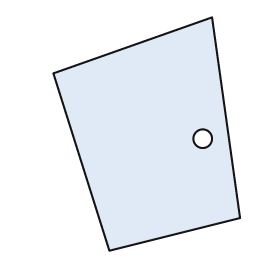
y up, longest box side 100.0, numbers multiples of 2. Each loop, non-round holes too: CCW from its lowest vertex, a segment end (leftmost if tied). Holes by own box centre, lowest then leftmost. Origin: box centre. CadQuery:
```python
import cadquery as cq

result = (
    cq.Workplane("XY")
    .moveTo(-16.0, -50.0)
    .lineTo(40.0, -36.0)
    .lineTo(28.0, 50.0)
    .lineTo(-40.0, 26.0)
    .close()
    .moveTo(24.0, -2.0)
    .circle(4.0)
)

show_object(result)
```